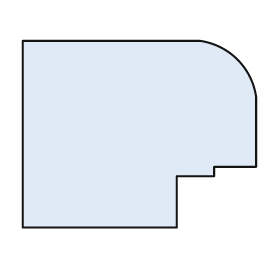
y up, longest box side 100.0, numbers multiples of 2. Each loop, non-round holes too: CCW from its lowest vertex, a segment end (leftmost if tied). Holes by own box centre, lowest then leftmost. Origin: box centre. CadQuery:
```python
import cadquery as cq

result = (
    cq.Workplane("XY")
    .moveTo(-50.0, -40.0)
    .lineTo(16.0, -40.0)
    .lineTo(16.0, -18.0)
    .lineTo(32.0, -18.0)
    .lineTo(32.0, -14.0)
    .lineTo(50.0, -14.0)
    .lineTo(50.0, 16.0)
    .threePointArc((42.0, 32.0), (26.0, 40.0))
    .lineTo(-50.0, 40.0)
    .close()
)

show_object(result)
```